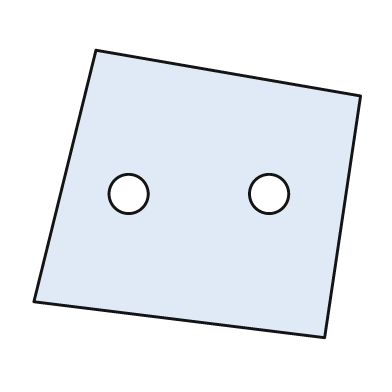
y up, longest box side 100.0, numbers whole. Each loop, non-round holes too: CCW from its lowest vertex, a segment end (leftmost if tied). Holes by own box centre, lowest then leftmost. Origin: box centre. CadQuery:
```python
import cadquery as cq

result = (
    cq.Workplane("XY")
    .moveTo(39.0, -44.0)
    .lineTo(50.0, 30.0)
    .lineTo(-31.0, 44.0)
    .lineTo(-50.0, -33.0)
    .close()
    .moveTo(-21.0, 0.0)
    .circle(6.0)
    .moveTo(22.0, 0.0)
    .circle(6.0)
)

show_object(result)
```